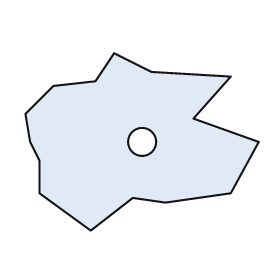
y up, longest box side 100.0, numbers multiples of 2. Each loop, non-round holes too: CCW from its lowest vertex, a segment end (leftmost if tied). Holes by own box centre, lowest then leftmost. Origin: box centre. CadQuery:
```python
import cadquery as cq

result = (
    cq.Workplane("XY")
    .moveTo(-22.0, -38.0)
    .lineTo(-4.0, -24.0)
    .lineTo(10.0, -26.0)
    .lineTo(38.0, -22.0)
    .lineTo(50.0, 0.0)
    .lineTo(22.0, 10.0)
    .lineTo(38.0, 28.0)
    .lineTo(4.0, 30.0)
    .lineTo(-12.0, 38.0)
    .lineTo(-20.0, 26.0)
    .lineTo(-38.0, 24.0)
    .lineTo(-50.0, 12.0)
    .lineTo(-48.0, 0.0)
    .lineTo(-44.0, -8.0)
    .lineTo(-44.0, -22.0)
    .close()
    .moveTo(0.0, 0.0)
    .circle(6.0)
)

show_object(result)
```